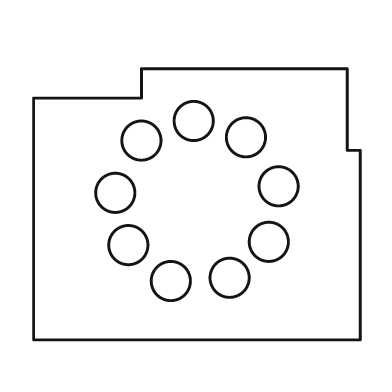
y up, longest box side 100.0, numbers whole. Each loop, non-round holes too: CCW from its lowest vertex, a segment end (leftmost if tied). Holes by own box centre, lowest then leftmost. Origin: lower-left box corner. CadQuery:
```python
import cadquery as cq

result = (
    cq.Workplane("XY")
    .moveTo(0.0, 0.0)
    .lineTo(100.0, 0.0)
    .lineTo(100.0, 58.0)
    .lineTo(96.0, 58.0)
    .lineTo(96.0, 83.0)
    .lineTo(33.0, 83.0)
    .lineTo(33.0, 74.0)
    .lineTo(0.0, 74.0)
    .close()
    .moveTo(42.0, 18.0)
    .circle(6.0)
    .moveTo(60.0, 19.0)
    .circle(6.0)
    .moveTo(29.0, 29.0)
    .circle(6.0)
    .moveTo(72.0, 30.0)
    .circle(6.0)
    .moveTo(25.0, 45.0)
    .circle(6.0)
    .moveTo(75.0, 47.0)
    .circle(6.0)
    .moveTo(33.0, 61.0)
    .circle(6.0)
    .moveTo(65.0, 62.0)
    .circle(6.0)
    .moveTo(49.0, 67.0)
    .circle(6.0)
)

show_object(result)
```